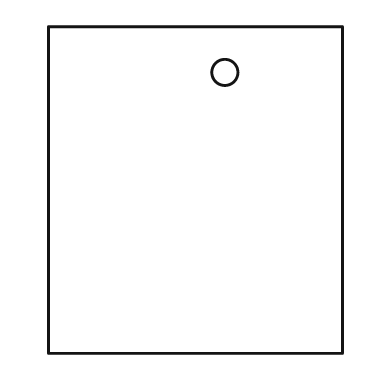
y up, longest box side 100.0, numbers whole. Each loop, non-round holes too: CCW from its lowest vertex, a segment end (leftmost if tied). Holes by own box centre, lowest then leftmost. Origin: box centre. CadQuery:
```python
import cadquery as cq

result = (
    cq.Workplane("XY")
    .moveTo(-45.0, -50.0)
    .lineTo(45.0, -50.0)
    .lineTo(45.0, 50.0)
    .lineTo(-45.0, 50.0)
    .close()
    .moveTo(9.0, 36.0)
    .circle(4.0)
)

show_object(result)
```